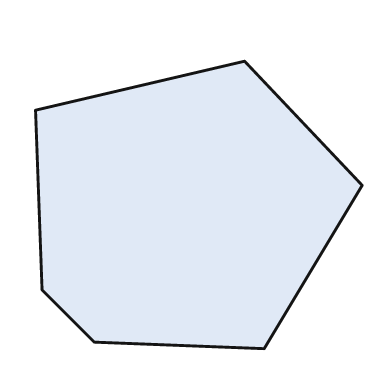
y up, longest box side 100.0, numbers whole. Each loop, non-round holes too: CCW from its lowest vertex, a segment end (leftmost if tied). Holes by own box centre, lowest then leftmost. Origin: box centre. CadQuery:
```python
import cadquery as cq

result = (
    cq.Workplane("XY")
    .moveTo(20.0, -44.0)
    .lineTo(50.0, 6.0)
    .lineTo(14.0, 44.0)
    .lineTo(-50.0, 29.0)
    .lineTo(-48.0, -26.0)
    .lineTo(-32.0, -42.0)
    .close()
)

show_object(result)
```